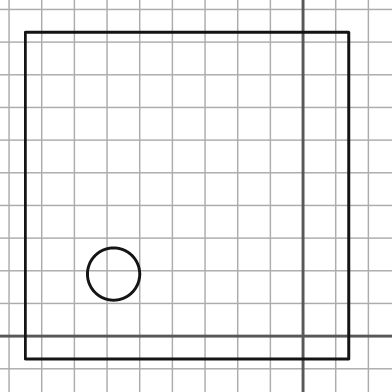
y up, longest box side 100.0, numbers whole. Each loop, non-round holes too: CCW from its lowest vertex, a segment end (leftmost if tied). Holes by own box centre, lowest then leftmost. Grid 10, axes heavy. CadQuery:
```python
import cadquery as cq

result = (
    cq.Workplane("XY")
    .moveTo(-85.0, -7.0)
    .lineTo(14.0, -7.0)
    .lineTo(14.0, 93.0)
    .lineTo(-85.0, 93.0)
    .close()
    .moveTo(-58.0, 19.0)
    .circle(8.0)
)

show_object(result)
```